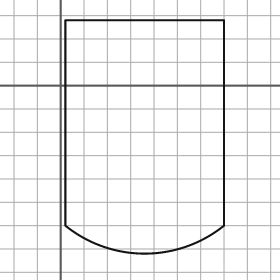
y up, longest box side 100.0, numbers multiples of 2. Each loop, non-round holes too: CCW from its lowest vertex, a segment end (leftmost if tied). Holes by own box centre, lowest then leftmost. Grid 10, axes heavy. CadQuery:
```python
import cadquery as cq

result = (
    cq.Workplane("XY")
    .moveTo(2.0, -60.0)
    .threePointArc((36.0, -72.0), (70.0, -60.0))
    .lineTo(70.0, 28.0)
    .lineTo(2.0, 28.0)
    .close()
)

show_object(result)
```